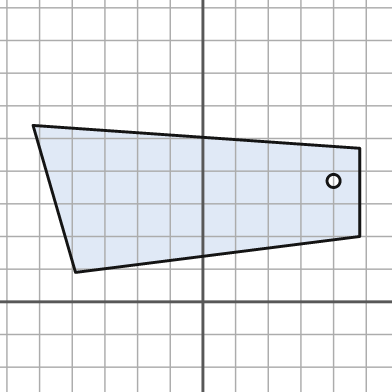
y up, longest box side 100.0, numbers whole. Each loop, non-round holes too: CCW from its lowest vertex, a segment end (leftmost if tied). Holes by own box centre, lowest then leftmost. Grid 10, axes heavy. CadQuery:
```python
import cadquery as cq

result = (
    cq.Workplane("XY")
    .moveTo(-39.0, 9.0)
    .lineTo(48.0, 20.0)
    .lineTo(48.0, 47.0)
    .lineTo(-52.0, 54.0)
    .close()
    .moveTo(40.0, 37.0)
    .circle(2.0)
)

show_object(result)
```